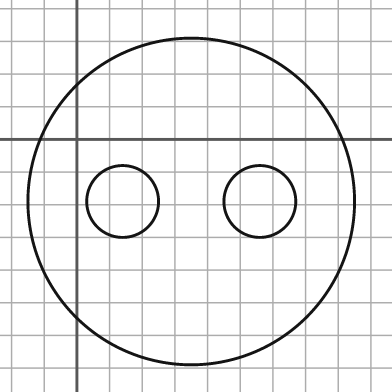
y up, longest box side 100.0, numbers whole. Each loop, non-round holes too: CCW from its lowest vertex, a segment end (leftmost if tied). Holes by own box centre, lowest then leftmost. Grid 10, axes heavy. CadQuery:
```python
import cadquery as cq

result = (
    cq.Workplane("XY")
    .moveTo(35.0, -19.0)
    .circle(50.0)
    .moveTo(14.0, -19.0)
    .circle(11.0)
    .moveTo(56.0, -19.0)
    .circle(11.0)
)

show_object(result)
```